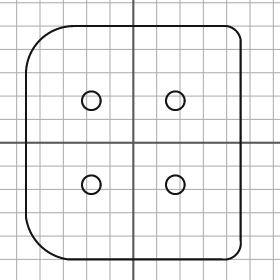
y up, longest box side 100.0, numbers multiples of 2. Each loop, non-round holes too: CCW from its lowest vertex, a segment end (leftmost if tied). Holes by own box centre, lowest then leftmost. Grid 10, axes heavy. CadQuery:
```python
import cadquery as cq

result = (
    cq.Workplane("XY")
    .moveTo(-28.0, -50.0)
    .lineTo(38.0, -50.0)
    .threePointArc((44.0, -48.0), (46.0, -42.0))
    .lineTo(46.0, 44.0)
    .threePointArc((44.0, 48.0), (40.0, 50.0))
    .lineTo(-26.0, 50.0)
    .threePointArc((-40.0, 44.0), (-46.0, 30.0))
    .lineTo(-46.0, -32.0)
    .threePointArc((-40.0, -44.0), (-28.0, -50.0))
    .close()
    .moveTo(-18.0, -18.0)
    .circle(4.0)
    .moveTo(18.0, -18.0)
    .circle(4.0)
    .moveTo(-18.0, 18.0)
    .circle(4.0)
    .moveTo(18.0, 18.0)
    .circle(4.0)
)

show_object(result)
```